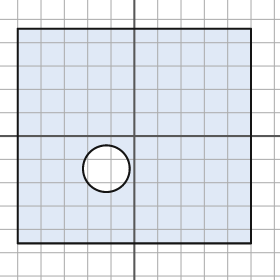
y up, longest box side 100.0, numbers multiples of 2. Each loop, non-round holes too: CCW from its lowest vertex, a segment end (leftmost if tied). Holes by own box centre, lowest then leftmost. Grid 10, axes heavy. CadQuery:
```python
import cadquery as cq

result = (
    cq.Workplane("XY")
    .moveTo(-50.0, -46.0)
    .lineTo(50.0, -46.0)
    .lineTo(50.0, 46.0)
    .lineTo(-50.0, 46.0)
    .close()
    .moveTo(-12.0, -14.0)
    .circle(10.0)
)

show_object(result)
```